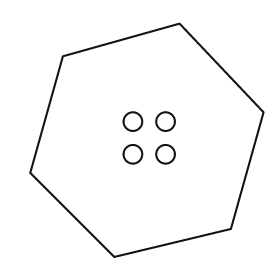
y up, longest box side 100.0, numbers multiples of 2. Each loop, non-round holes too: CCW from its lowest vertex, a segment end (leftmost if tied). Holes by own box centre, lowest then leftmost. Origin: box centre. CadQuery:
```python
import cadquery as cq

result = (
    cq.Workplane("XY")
    .moveTo(-14.0, -50.0)
    .lineTo(36.0, -38.0)
    .lineTo(50.0, 12.0)
    .lineTo(14.0, 50.0)
    .lineTo(-36.0, 36.0)
    .lineTo(-50.0, -14.0)
    .close()
    .moveTo(-6.0, -6.0)
    .circle(4.0)
    .moveTo(8.0, -6.0)
    .circle(4.0)
    .moveTo(-6.0, 8.0)
    .circle(4.0)
    .moveTo(8.0, 8.0)
    .circle(4.0)
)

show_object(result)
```